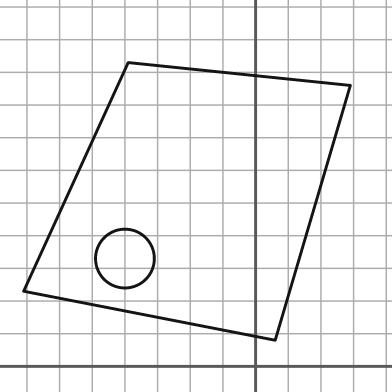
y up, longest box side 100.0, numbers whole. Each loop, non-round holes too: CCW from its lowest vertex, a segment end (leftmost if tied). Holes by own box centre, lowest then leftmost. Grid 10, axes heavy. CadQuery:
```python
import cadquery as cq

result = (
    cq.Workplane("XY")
    .moveTo(6.0, 8.0)
    .lineTo(29.0, 86.0)
    .lineTo(-39.0, 93.0)
    .lineTo(-71.0, 23.0)
    .close()
    .moveTo(-40.0, 33.0)
    .circle(9.0)
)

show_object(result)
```